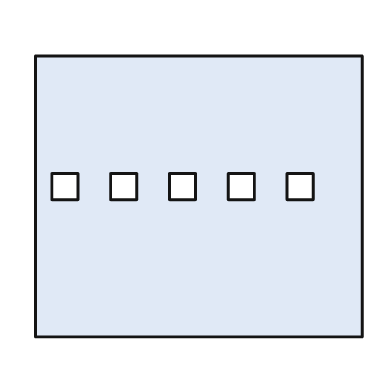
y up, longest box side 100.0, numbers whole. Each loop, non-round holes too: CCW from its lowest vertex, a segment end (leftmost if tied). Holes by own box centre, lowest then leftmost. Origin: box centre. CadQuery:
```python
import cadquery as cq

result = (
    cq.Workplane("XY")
    .moveTo(-50.0, -43.0)
    .lineTo(50.0, -43.0)
    .lineTo(50.0, 43.0)
    .lineTo(-50.0, 43.0)
    .close()
    .moveTo(-45.0, -1.0)
    .lineTo(-37.0, -1.0)
    .lineTo(-37.0, 7.0)
    .lineTo(-45.0, 7.0)
    .close()
    .moveTo(-27.0, -1.0)
    .lineTo(-19.0, -1.0)
    .lineTo(-19.0, 7.0)
    .lineTo(-27.0, 7.0)
    .close()
    .moveTo(-9.0, -1.0)
    .lineTo(-1.0, -1.0)
    .lineTo(-1.0, 7.0)
    .lineTo(-9.0, 7.0)
    .close()
    .moveTo(9.0, -1.0)
    .lineTo(17.0, -1.0)
    .lineTo(17.0, 7.0)
    .lineTo(9.0, 7.0)
    .close()
    .moveTo(27.0, -1.0)
    .lineTo(35.0, -1.0)
    .lineTo(35.0, 7.0)
    .lineTo(27.0, 7.0)
    .close()
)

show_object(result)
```